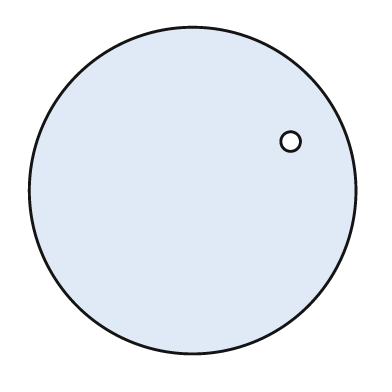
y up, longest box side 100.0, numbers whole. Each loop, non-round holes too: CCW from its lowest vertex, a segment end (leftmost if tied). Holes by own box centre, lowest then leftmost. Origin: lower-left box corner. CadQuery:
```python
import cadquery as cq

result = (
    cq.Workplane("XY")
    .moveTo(50.0, 50.0)
    .circle(50.0)
    .moveTo(80.0, 65.0)
    .circle(3.0)
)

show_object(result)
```